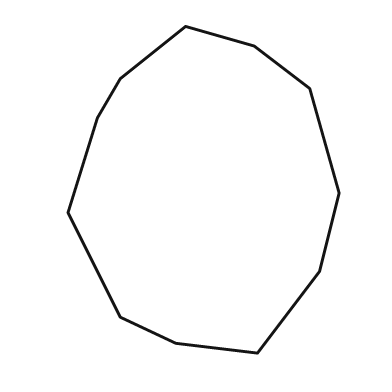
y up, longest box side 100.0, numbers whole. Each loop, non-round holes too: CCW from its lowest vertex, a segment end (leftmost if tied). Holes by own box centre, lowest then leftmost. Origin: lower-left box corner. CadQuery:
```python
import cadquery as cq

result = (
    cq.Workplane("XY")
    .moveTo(58.0, 0.0)
    .lineTo(77.0, 25.0)
    .lineTo(83.0, 49.0)
    .lineTo(74.0, 81.0)
    .lineTo(57.0, 94.0)
    .lineTo(36.0, 100.0)
    .lineTo(16.0, 84.0)
    .lineTo(9.0, 72.0)
    .lineTo(0.0, 43.0)
    .lineTo(16.0, 11.0)
    .lineTo(33.0, 3.0)
    .close()
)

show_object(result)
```